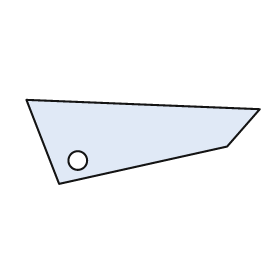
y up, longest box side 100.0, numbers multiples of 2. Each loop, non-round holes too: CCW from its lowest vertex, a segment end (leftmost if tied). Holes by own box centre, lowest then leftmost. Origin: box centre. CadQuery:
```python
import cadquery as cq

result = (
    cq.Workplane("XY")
    .moveTo(-36.0, -18.0)
    .lineTo(36.0, -2.0)
    .lineTo(50.0, 14.0)
    .lineTo(-50.0, 18.0)
    .close()
    .moveTo(-28.0, -8.0)
    .circle(4.0)
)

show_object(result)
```